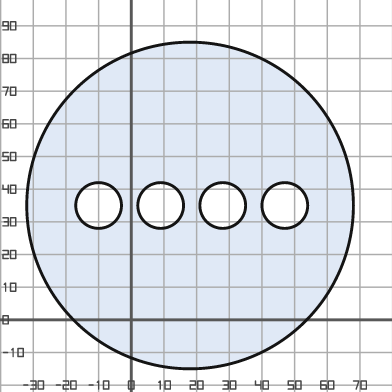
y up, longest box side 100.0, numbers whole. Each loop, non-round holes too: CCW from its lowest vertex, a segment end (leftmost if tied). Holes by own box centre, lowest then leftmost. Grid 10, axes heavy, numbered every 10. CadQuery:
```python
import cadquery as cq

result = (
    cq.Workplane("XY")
    .moveTo(18.0, 35.0)
    .circle(50.0)
    .moveTo(-10.0, 35.0)
    .circle(7.0)
    .moveTo(9.0, 35.0)
    .circle(7.0)
    .moveTo(28.0, 35.0)
    .circle(7.0)
    .moveTo(47.0, 35.0)
    .circle(7.0)
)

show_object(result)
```